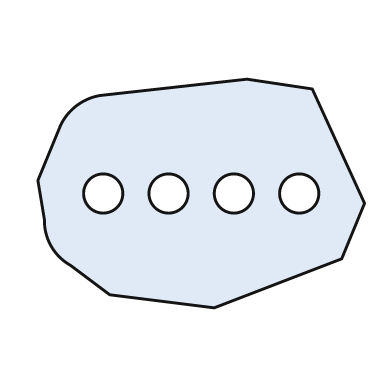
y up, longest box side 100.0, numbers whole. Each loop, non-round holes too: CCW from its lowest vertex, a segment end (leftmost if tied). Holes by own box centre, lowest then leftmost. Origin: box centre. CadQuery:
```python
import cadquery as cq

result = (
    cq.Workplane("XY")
    .moveTo(4.0, -35.0)
    .lineTo(43.0, -20.0)
    .lineTo(50.0, -3.0)
    .lineTo(34.0, 32.0)
    .lineTo(14.0, 35.0)
    .lineTo(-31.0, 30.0)
    .threePointArc((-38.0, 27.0), (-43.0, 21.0))
    .lineTo(-50.0, 4.0)
    .lineTo(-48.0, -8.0)
    .threePointArc((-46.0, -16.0), (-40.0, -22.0))
    .lineTo(-28.0, -31.0)
    .close()
    .moveTo(-30.0, 0.0)
    .circle(6.0)
    .moveTo(-10.0, 0.0)
    .circle(6.0)
    .moveTo(10.0, 0.0)
    .circle(6.0)
    .moveTo(30.0, 0.0)
    .circle(6.0)
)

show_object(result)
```